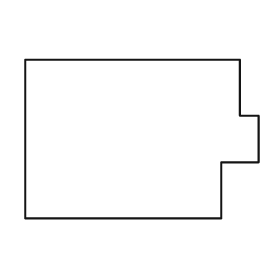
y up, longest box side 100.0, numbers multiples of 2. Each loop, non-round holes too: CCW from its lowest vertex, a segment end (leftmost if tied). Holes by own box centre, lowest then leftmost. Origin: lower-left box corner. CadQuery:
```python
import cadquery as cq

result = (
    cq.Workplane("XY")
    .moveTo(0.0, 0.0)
    .lineTo(84.0, 0.0)
    .lineTo(84.0, 24.0)
    .lineTo(100.0, 24.0)
    .lineTo(100.0, 44.0)
    .lineTo(92.0, 44.0)
    .lineTo(92.0, 68.0)
    .lineTo(0.0, 68.0)
    .close()
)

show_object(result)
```